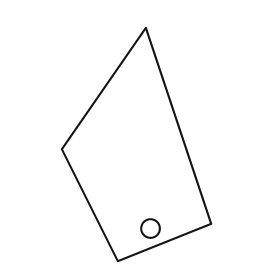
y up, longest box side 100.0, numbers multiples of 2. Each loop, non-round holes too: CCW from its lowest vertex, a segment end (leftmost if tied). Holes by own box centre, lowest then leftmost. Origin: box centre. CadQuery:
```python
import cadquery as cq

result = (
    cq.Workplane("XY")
    .moveTo(-8.0, -50.0)
    .lineTo(32.0, -34.0)
    .lineTo(4.0, 50.0)
    .lineTo(-32.0, -2.0)
    .close()
    .moveTo(6.0, -36.0)
    .circle(4.0)
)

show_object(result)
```